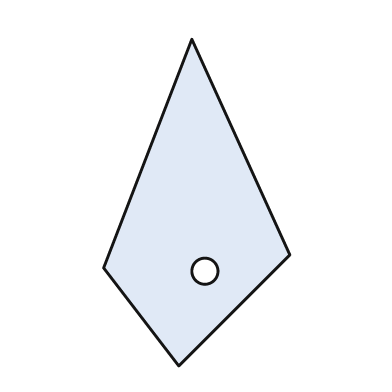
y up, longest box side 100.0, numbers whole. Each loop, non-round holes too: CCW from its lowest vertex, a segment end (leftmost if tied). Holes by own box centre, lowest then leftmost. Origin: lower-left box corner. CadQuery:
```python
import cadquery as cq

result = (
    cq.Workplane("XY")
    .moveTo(23.0, 0.0)
    .lineTo(57.0, 34.0)
    .lineTo(27.0, 100.0)
    .lineTo(0.0, 30.0)
    .close()
    .moveTo(31.0, 29.0)
    .circle(4.0)
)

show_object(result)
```